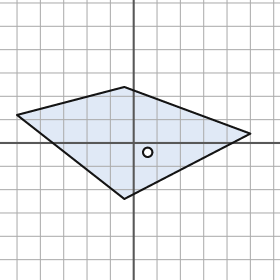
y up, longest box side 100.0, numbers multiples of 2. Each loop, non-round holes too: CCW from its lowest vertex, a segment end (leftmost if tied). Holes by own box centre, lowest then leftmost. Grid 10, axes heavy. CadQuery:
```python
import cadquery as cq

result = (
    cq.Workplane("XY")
    .moveTo(-4.0, -24.0)
    .lineTo(50.0, 4.0)
    .lineTo(-4.0, 24.0)
    .lineTo(-50.0, 12.0)
    .close()
    .moveTo(6.0, -4.0)
    .circle(2.0)
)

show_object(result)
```